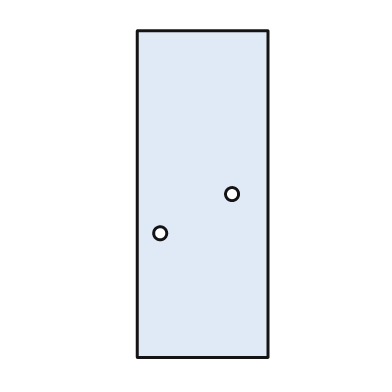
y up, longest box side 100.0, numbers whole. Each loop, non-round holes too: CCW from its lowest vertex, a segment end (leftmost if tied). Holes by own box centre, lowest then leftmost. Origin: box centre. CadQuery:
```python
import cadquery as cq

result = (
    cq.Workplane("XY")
    .moveTo(-20.0, -50.0)
    .lineTo(20.0, -50.0)
    .lineTo(20.0, 50.0)
    .lineTo(-20.0, 50.0)
    .close()
    .moveTo(-13.0, -12.0)
    .circle(2.0)
    .moveTo(9.0, 0.0)
    .circle(2.0)
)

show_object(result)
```